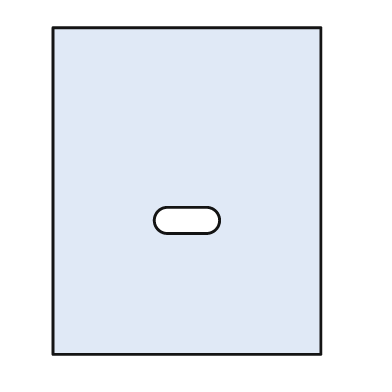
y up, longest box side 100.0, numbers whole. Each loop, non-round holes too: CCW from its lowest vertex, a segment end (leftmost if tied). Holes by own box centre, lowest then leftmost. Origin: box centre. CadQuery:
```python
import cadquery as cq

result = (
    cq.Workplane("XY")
    .moveTo(-41.0, -50.0)
    .lineTo(41.0, -50.0)
    .lineTo(41.0, 50.0)
    .lineTo(-41.0, 50.0)
    .close()
    .moveTo(-6.0, -13.0)
    .lineTo(6.0, -13.0)
    .threePointArc((10.0, -9.0), (6.0, -5.0))
    .lineTo(-6.0, -5.0)
    .threePointArc((-10.0, -9.0), (-6.0, -13.0))
    .close()
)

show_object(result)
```